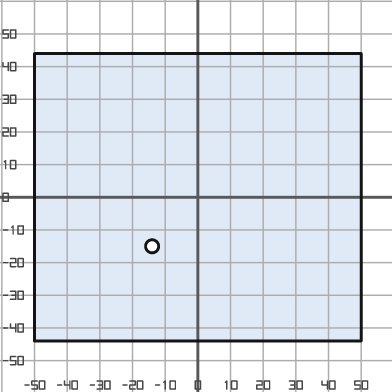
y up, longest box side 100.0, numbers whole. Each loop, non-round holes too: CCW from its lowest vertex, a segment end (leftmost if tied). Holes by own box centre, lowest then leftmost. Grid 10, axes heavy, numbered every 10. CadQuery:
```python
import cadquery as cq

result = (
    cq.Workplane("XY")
    .moveTo(-50.0, -44.0)
    .lineTo(50.0, -44.0)
    .lineTo(50.0, 44.0)
    .lineTo(-50.0, 44.0)
    .close()
    .moveTo(-14.0, -15.0)
    .circle(2.0)
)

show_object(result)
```